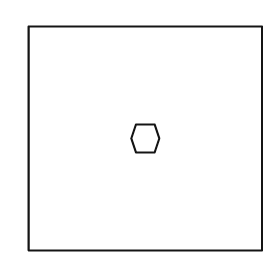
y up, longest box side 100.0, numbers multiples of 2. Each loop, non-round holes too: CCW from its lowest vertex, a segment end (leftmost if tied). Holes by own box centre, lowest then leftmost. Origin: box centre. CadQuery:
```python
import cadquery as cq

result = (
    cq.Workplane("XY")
    .moveTo(-50.0, -48.0)
    .lineTo(50.0, -48.0)
    .lineTo(50.0, 48.0)
    .lineTo(-50.0, 48.0)
    .close()
    .moveTo(-4.0, -6.0)
    .lineTo(4.0, -6.0)
    .lineTo(6.0, 0.0)
    .lineTo(4.0, 6.0)
    .lineTo(-4.0, 6.0)
    .lineTo(-6.0, 0.0)
    .close()
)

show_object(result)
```